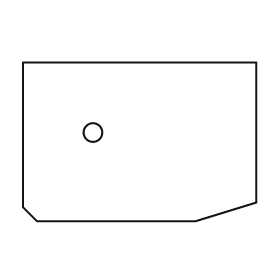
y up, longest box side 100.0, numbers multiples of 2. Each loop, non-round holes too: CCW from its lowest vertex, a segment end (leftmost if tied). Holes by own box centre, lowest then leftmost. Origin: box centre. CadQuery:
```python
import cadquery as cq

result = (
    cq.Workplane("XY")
    .moveTo(-44.0, -34.0)
    .lineTo(24.0, -34.0)
    .lineTo(50.0, -26.0)
    .lineTo(50.0, 34.0)
    .lineTo(-50.0, 34.0)
    .lineTo(-50.0, -28.0)
    .close()
    .moveTo(-20.0, 4.0)
    .circle(4.0)
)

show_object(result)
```